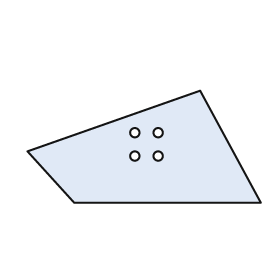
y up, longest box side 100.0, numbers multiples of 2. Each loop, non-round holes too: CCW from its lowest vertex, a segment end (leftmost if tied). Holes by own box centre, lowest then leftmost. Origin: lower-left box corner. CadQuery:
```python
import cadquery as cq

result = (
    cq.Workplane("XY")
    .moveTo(20.0, 0.0)
    .lineTo(100.0, 0.0)
    .lineTo(74.0, 48.0)
    .lineTo(0.0, 22.0)
    .close()
    .moveTo(46.0, 20.0)
    .circle(2.0)
    .moveTo(56.0, 20.0)
    .circle(2.0)
    .moveTo(46.0, 30.0)
    .circle(2.0)
    .moveTo(56.0, 30.0)
    .circle(2.0)
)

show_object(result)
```